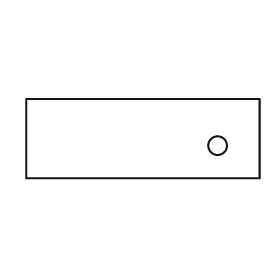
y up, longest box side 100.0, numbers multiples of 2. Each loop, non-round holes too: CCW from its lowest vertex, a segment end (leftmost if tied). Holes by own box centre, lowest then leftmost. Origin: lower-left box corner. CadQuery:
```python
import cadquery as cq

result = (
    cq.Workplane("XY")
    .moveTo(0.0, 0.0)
    .lineTo(100.0, 0.0)
    .lineTo(100.0, 34.0)
    .lineTo(0.0, 34.0)
    .close()
    .moveTo(82.0, 14.0)
    .circle(4.0)
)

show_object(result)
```